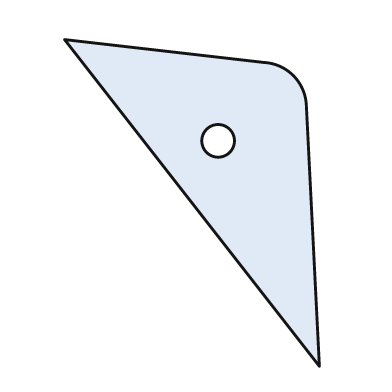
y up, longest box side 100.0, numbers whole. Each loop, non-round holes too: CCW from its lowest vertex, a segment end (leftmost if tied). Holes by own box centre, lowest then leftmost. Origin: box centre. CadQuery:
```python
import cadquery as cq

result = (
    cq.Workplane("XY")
    .moveTo(39.0, -50.0)
    .lineTo(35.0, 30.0)
    .threePointArc((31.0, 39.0), (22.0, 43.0))
    .lineTo(-39.0, 50.0)
    .close()
    .moveTo(8.0, 19.0)
    .circle(5.0)
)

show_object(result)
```